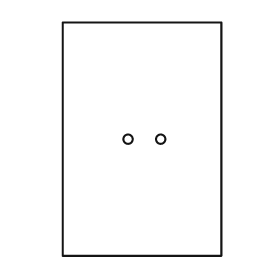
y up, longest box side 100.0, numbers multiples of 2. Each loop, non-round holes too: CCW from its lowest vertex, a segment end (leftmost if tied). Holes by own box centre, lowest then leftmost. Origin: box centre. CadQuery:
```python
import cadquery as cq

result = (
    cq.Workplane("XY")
    .moveTo(-34.0, -50.0)
    .lineTo(34.0, -50.0)
    .lineTo(34.0, 50.0)
    .lineTo(-34.0, 50.0)
    .close()
    .moveTo(-6.0, 0.0)
    .circle(2.0)
    .moveTo(8.0, 0.0)
    .circle(2.0)
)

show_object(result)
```